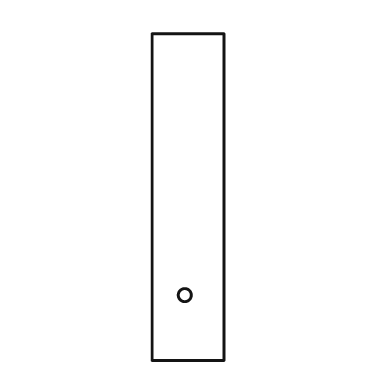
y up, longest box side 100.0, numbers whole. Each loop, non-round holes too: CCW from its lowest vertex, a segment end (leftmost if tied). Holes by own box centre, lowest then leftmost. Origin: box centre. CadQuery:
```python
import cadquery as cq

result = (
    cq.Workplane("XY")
    .moveTo(-11.0, -50.0)
    .lineTo(11.0, -50.0)
    .lineTo(11.0, 50.0)
    .lineTo(-11.0, 50.0)
    .close()
    .moveTo(-1.0, -30.0)
    .circle(2.0)
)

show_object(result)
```